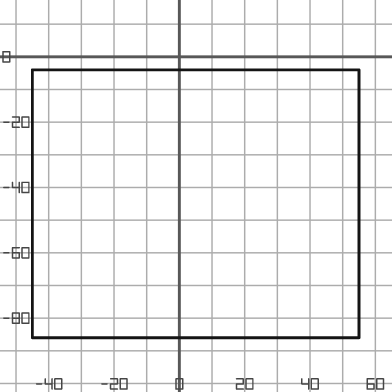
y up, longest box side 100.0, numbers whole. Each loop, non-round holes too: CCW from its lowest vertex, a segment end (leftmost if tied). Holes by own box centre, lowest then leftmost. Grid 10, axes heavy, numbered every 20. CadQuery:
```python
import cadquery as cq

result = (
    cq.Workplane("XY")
    .moveTo(-45.0, -86.0)
    .lineTo(55.0, -86.0)
    .lineTo(55.0, -4.0)
    .lineTo(-45.0, -4.0)
    .close()
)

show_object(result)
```